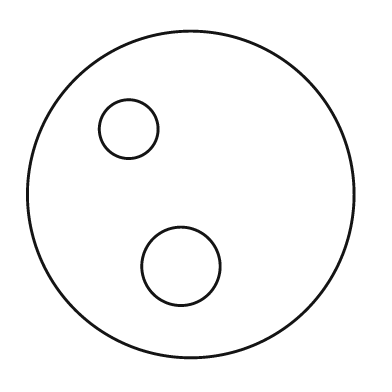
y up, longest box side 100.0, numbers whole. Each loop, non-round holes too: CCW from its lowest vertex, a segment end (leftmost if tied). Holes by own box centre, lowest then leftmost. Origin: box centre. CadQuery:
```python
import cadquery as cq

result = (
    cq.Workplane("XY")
    .moveTo(0.0, 0.0)
    .circle(50.0)
    .moveTo(-3.0, -22.0)
    .circle(12.0)
    .moveTo(-19.0, 20.0)
    .circle(9.0)
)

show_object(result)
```